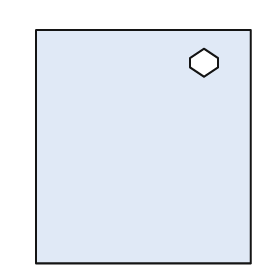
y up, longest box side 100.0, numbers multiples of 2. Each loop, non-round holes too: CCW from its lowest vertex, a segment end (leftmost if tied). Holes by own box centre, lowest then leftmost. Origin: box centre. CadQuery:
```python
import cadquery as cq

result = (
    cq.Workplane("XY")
    .moveTo(-46.0, -50.0)
    .lineTo(46.0, -50.0)
    .lineTo(46.0, 50.0)
    .lineTo(-46.0, 50.0)
    .close()
    .moveTo(26.0, 30.0)
    .lineTo(32.0, 34.0)
    .lineTo(32.0, 38.0)
    .lineTo(26.0, 42.0)
    .lineTo(20.0, 38.0)
    .lineTo(20.0, 34.0)
    .close()
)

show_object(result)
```